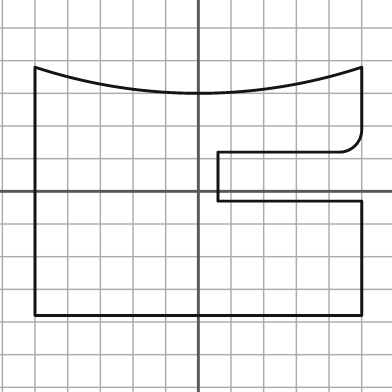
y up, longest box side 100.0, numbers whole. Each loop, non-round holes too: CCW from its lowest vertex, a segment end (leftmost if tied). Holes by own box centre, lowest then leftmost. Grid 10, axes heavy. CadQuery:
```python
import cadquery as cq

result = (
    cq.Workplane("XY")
    .moveTo(-50.0, -38.0)
    .lineTo(50.0, -38.0)
    .lineTo(50.0, -3.0)
    .lineTo(6.0, -3.0)
    .lineTo(6.0, 12.0)
    .lineTo(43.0, 12.0)
    .threePointArc((48.0, 14.0), (50.0, 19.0))
    .lineTo(50.0, 38.0)
    .threePointArc((0.0, 30.0), (-50.0, 38.0))
    .close()
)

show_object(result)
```